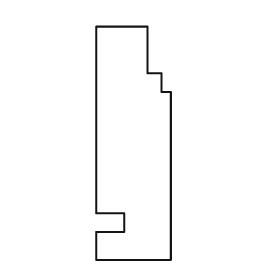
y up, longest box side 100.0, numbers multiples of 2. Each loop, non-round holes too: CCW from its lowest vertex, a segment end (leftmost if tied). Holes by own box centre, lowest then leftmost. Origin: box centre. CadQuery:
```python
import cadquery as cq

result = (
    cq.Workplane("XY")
    .moveTo(-16.0, -50.0)
    .lineTo(16.0, -50.0)
    .lineTo(16.0, 22.0)
    .lineTo(12.0, 22.0)
    .lineTo(12.0, 30.0)
    .lineTo(6.0, 30.0)
    .lineTo(6.0, 50.0)
    .lineTo(-16.0, 50.0)
    .lineTo(-16.0, -30.0)
    .lineTo(-4.0, -30.0)
    .lineTo(-4.0, -38.0)
    .lineTo(-16.0, -38.0)
    .close()
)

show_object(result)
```